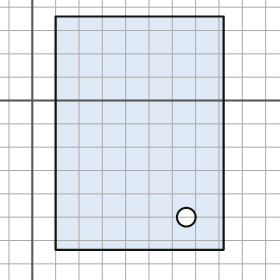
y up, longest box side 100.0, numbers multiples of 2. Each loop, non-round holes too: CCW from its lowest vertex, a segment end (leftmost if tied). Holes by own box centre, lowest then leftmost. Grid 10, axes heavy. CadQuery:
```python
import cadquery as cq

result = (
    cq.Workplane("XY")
    .moveTo(10.0, -64.0)
    .lineTo(82.0, -64.0)
    .lineTo(82.0, 36.0)
    .lineTo(10.0, 36.0)
    .close()
    .moveTo(66.0, -50.0)
    .circle(4.0)
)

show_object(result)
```